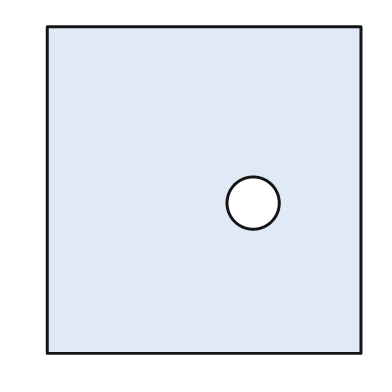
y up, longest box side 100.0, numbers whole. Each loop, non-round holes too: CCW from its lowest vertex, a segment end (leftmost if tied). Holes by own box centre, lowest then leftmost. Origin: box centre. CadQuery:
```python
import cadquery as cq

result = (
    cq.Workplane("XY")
    .moveTo(-48.0, -50.0)
    .lineTo(48.0, -50.0)
    .lineTo(48.0, 50.0)
    .lineTo(-48.0, 50.0)
    .close()
    .moveTo(15.0, -4.0)
    .circle(8.0)
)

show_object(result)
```